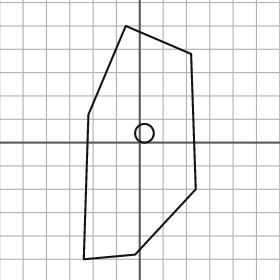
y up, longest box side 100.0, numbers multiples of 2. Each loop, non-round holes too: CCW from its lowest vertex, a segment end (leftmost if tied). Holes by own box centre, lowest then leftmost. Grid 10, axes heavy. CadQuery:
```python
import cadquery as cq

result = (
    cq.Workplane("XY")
    .moveTo(-24.0, -50.0)
    .lineTo(-2.0, -48.0)
    .lineTo(24.0, -20.0)
    .lineTo(22.0, 38.0)
    .lineTo(-6.0, 50.0)
    .lineTo(-22.0, 12.0)
    .close()
    .moveTo(2.0, 4.0)
    .circle(4.0)
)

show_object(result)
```